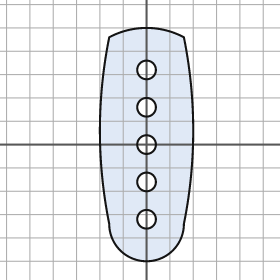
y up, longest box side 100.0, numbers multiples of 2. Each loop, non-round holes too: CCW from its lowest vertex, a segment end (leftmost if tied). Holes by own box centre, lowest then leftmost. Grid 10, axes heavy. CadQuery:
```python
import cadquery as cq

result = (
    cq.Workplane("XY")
    .moveTo(-16.0, -34.0)
    .threePointArc((0.0, -50.0), (16.0, -34.0))
    .threePointArc((20.0, 6.0), (16.0, 46.0))
    .threePointArc((0.0, 50.0), (-16.0, 46.0))
    .threePointArc((-20.0, 6.0), (-16.0, -34.0))
    .close()
    .moveTo(0.0, -32.0)
    .circle(4.0)
    .moveTo(0.0, -16.0)
    .circle(4.0)
    .moveTo(0.0, 0.0)
    .circle(4.0)
    .moveTo(0.0, 16.0)
    .circle(4.0)
    .moveTo(0.0, 32.0)
    .circle(4.0)
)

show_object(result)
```